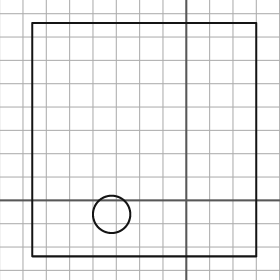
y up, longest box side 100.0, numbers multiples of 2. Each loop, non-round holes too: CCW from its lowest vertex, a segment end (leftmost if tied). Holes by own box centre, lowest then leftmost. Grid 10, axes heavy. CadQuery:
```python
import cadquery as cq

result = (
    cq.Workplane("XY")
    .moveTo(-66.0, -24.0)
    .lineTo(30.0, -24.0)
    .lineTo(30.0, 76.0)
    .lineTo(-66.0, 76.0)
    .close()
    .moveTo(-32.0, -6.0)
    .circle(8.0)
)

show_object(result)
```